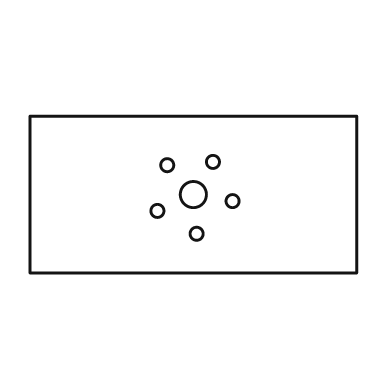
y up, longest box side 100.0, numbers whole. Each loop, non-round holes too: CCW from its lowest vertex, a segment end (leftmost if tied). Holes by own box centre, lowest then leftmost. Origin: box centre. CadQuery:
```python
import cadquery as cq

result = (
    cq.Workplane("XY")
    .moveTo(-50.0, -24.0)
    .lineTo(50.0, -24.0)
    .lineTo(50.0, 24.0)
    .lineTo(-50.0, 24.0)
    .close()
    .moveTo(1.0, -12.0)
    .circle(2.0)
    .moveTo(-11.0, -5.0)
    .circle(2.0)
    .moveTo(12.0, -2.0)
    .circle(2.0)
    .moveTo(0.0, 0.0)
    .circle(4.0)
    .moveTo(-8.0, 9.0)
    .circle(2.0)
    .moveTo(6.0, 10.0)
    .circle(2.0)
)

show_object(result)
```